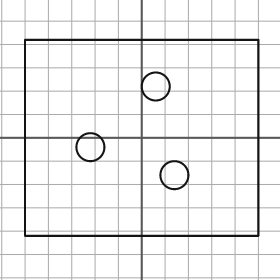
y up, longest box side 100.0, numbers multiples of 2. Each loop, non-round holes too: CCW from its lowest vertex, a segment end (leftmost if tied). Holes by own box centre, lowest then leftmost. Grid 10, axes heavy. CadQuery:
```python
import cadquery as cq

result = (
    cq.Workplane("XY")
    .moveTo(-50.0, -42.0)
    .lineTo(50.0, -42.0)
    .lineTo(50.0, 42.0)
    .lineTo(-50.0, 42.0)
    .close()
    .moveTo(14.0, -16.0)
    .circle(6.0)
    .moveTo(-22.0, -4.0)
    .circle(6.0)
    .moveTo(6.0, 22.0)
    .circle(6.0)
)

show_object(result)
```